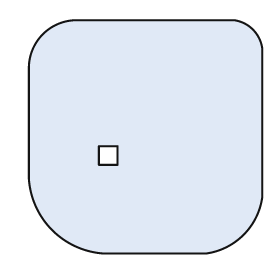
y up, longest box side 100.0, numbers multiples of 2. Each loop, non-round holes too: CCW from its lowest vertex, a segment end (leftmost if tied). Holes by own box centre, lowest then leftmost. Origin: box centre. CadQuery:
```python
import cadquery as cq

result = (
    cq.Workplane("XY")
    .moveTo(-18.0, -50.0)
    .lineTo(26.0, -50.0)
    .threePointArc((42.0, -42.0), (50.0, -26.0))
    .lineTo(50.0, 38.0)
    .threePointArc((46.0, 46.0), (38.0, 50.0))
    .lineTo(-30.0, 50.0)
    .threePointArc((-44.0, 44.0), (-50.0, 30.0))
    .lineTo(-50.0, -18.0)
    .threePointArc((-40.0, -40.0), (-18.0, -50.0))
    .close()
    .moveTo(-20.0, -12.0)
    .lineTo(-12.0, -12.0)
    .lineTo(-12.0, -4.0)
    .lineTo(-20.0, -4.0)
    .close()
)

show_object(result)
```